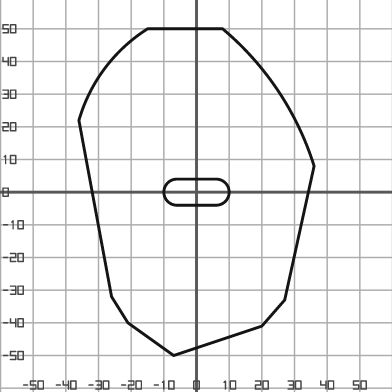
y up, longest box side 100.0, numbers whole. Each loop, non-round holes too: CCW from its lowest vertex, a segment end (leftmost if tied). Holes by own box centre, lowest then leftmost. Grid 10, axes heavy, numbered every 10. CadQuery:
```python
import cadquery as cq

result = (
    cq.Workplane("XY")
    .moveTo(-7.0, -50.0)
    .lineTo(20.0, -41.0)
    .lineTo(27.0, -33.0)
    .lineTo(36.0, 8.0)
    .threePointArc((25.0, 31.0), (8.0, 50.0))
    .lineTo(-15.0, 50.0)
    .threePointArc((-28.0, 38.0), (-36.0, 22.0))
    .lineTo(-26.0, -32.0)
    .lineTo(-21.0, -40.0)
    .close()
    .moveTo(-6.0, -4.0)
    .lineTo(6.0, -4.0)
    .threePointArc((10.0, 0.0), (6.0, 4.0))
    .lineTo(-6.0, 4.0)
    .threePointArc((-10.0, 0.0), (-6.0, -4.0))
    .close()
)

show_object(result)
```